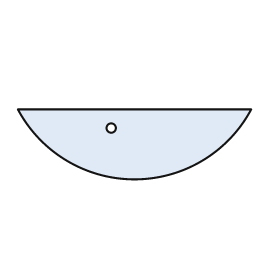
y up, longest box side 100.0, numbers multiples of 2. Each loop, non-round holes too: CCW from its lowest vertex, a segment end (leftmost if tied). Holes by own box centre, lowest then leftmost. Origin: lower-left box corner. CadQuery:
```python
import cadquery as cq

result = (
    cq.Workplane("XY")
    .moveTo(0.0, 30.0)
    .threePointArc((50.0, 0.0), (100.0, 30.0))
    .close()
    .moveTo(40.0, 22.0)
    .circle(2.0)
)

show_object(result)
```